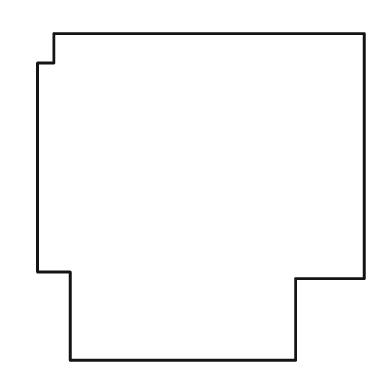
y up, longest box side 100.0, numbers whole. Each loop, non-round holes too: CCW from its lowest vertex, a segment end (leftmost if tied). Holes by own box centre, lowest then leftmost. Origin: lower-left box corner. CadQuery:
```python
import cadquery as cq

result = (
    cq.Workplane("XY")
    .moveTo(10.0, 0.0)
    .lineTo(79.0, 0.0)
    .lineTo(79.0, 25.0)
    .lineTo(100.0, 25.0)
    .lineTo(100.0, 100.0)
    .lineTo(5.0, 100.0)
    .lineTo(5.0, 91.0)
    .lineTo(0.0, 91.0)
    .lineTo(0.0, 27.0)
    .lineTo(10.0, 27.0)
    .close()
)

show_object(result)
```